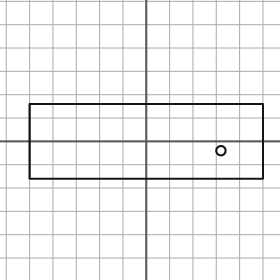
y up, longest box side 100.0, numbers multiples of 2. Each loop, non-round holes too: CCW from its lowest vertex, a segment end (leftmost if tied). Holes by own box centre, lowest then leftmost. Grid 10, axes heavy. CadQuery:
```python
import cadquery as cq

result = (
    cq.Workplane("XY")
    .moveTo(-50.0, -16.0)
    .lineTo(50.0, -16.0)
    .lineTo(50.0, 16.0)
    .lineTo(-50.0, 16.0)
    .close()
    .moveTo(32.0, -4.0)
    .circle(2.0)
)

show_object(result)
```